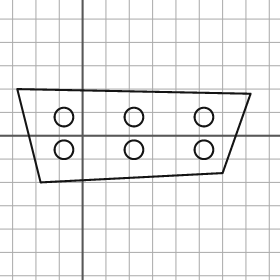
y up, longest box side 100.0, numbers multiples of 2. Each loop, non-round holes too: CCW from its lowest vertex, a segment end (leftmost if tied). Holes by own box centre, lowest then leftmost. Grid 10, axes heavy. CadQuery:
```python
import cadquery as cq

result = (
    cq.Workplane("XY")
    .moveTo(-18.0, -20.0)
    .lineTo(60.0, -16.0)
    .lineTo(72.0, 18.0)
    .lineTo(-28.0, 20.0)
    .close()
    .moveTo(-8.0, -6.0)
    .circle(4.0)
    .moveTo(22.0, -6.0)
    .circle(4.0)
    .moveTo(52.0, -6.0)
    .circle(4.0)
    .moveTo(-8.0, 8.0)
    .circle(4.0)
    .moveTo(22.0, 8.0)
    .circle(4.0)
    .moveTo(52.0, 8.0)
    .circle(4.0)
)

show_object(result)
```